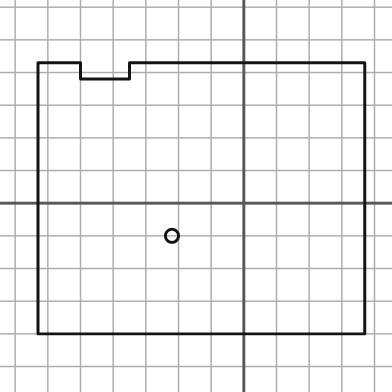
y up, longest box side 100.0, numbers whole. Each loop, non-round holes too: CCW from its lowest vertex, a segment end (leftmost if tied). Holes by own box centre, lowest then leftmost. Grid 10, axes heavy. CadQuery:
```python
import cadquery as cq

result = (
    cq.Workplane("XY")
    .moveTo(-63.0, -40.0)
    .lineTo(37.0, -40.0)
    .lineTo(37.0, 43.0)
    .lineTo(-35.0, 43.0)
    .lineTo(-35.0, 38.0)
    .lineTo(-50.0, 38.0)
    .lineTo(-50.0, 43.0)
    .lineTo(-63.0, 43.0)
    .close()
    .moveTo(-22.0, -10.0)
    .circle(2.0)
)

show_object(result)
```